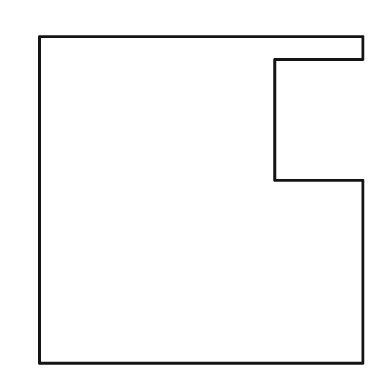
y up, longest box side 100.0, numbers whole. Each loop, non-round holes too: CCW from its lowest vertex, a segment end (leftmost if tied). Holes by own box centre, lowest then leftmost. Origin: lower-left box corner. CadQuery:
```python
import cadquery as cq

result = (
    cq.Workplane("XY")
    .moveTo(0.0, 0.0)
    .lineTo(99.0, 0.0)
    .lineTo(99.0, 56.0)
    .lineTo(72.0, 56.0)
    .lineTo(72.0, 93.0)
    .lineTo(99.0, 93.0)
    .lineTo(99.0, 100.0)
    .lineTo(0.0, 100.0)
    .close()
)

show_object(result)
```